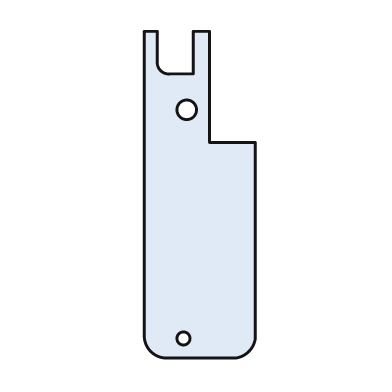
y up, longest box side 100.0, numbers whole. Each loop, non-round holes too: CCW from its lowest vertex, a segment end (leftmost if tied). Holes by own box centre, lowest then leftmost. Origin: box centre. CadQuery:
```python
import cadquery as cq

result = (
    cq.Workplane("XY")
    .moveTo(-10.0, -50.0)
    .lineTo(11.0, -50.0)
    .threePointArc((15.0, -48.0), (17.0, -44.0))
    .lineTo(17.0, 16.0)
    .lineTo(3.0, 16.0)
    .lineTo(3.0, 50.0)
    .lineTo(-2.0, 50.0)
    .lineTo(-2.0, 37.0)
    .lineTo(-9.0, 37.0)
    .threePointArc((-12.0, 38.0), (-13.0, 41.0))
    .lineTo(-13.0, 50.0)
    .lineTo(-17.0, 50.0)
    .lineTo(-17.0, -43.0)
    .threePointArc((-15.0, -48.0), (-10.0, -50.0))
    .close()
    .moveTo(-5.0, -44.0)
    .circle(2.0)
    .moveTo(-4.0, 26.0)
    .circle(3.0)
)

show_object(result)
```